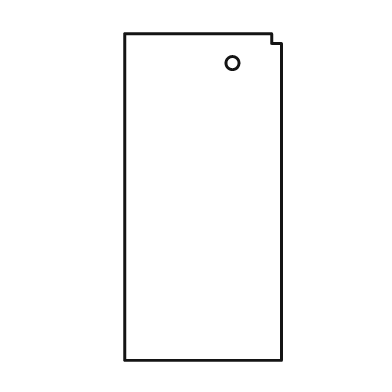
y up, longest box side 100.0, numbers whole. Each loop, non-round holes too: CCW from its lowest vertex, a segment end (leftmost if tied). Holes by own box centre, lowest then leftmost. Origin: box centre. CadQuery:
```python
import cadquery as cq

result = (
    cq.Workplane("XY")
    .moveTo(-24.0, -50.0)
    .lineTo(24.0, -50.0)
    .lineTo(24.0, 47.0)
    .lineTo(21.0, 47.0)
    .lineTo(21.0, 50.0)
    .lineTo(-24.0, 50.0)
    .close()
    .moveTo(9.0, 41.0)
    .circle(2.0)
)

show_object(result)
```